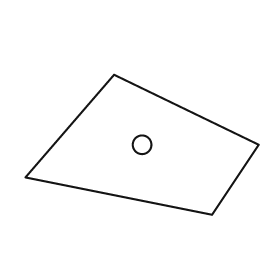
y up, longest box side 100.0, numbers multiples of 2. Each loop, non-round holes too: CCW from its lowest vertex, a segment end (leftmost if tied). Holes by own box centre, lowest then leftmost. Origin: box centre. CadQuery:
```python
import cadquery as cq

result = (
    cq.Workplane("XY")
    .moveTo(30.0, -30.0)
    .lineTo(50.0, 0.0)
    .lineTo(-12.0, 30.0)
    .lineTo(-50.0, -14.0)
    .close()
    .moveTo(0.0, 0.0)
    .circle(4.0)
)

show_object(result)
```